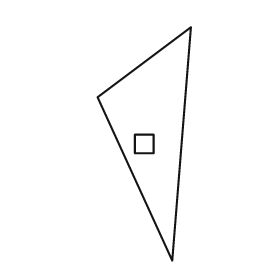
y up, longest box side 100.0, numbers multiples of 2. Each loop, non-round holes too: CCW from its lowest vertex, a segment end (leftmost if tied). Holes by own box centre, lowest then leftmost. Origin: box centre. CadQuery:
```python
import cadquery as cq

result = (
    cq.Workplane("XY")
    .moveTo(12.0, -50.0)
    .lineTo(20.0, 50.0)
    .lineTo(-20.0, 20.0)
    .close()
    .moveTo(-4.0, -4.0)
    .lineTo(4.0, -4.0)
    .lineTo(4.0, 4.0)
    .lineTo(-4.0, 4.0)
    .close()
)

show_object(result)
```